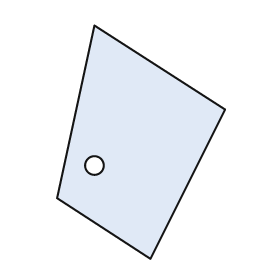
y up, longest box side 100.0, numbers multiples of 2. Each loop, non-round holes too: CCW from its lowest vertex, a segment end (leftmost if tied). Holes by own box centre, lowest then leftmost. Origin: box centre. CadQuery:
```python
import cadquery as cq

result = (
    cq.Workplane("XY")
    .moveTo(4.0, -50.0)
    .lineTo(36.0, 14.0)
    .lineTo(-20.0, 50.0)
    .lineTo(-36.0, -24.0)
    .close()
    .moveTo(-20.0, -10.0)
    .circle(4.0)
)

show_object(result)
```